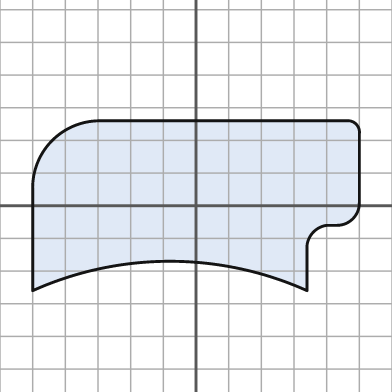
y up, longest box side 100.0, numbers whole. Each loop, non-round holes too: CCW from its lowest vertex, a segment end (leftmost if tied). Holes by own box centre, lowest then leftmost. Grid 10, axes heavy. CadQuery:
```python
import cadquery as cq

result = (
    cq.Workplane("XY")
    .moveTo(-50.0, -26.0)
    .threePointArc((-8.0, -17.0), (34.0, -26.0))
    .lineTo(34.0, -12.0)
    .threePointArc((36.0, -8.0), (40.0, -6.0))
    .lineTo(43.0, -6.0)
    .threePointArc((48.0, -4.0), (50.0, 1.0))
    .lineTo(50.0, 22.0)
    .threePointArc((49.0, 25.0), (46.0, 26.0))
    .lineTo(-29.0, 26.0)
    .threePointArc((-44.0, 20.0), (-50.0, 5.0))
    .close()
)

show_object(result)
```